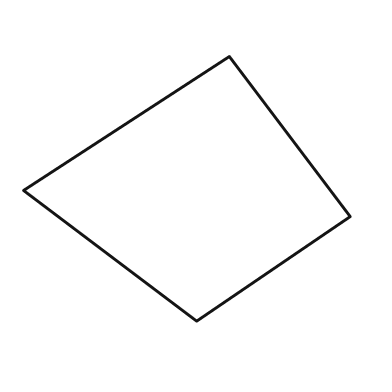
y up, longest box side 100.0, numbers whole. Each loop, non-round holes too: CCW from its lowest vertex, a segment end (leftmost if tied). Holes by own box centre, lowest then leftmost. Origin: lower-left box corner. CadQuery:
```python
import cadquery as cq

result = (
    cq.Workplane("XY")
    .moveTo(53.0, 0.0)
    .lineTo(100.0, 32.0)
    .lineTo(63.0, 81.0)
    .lineTo(0.0, 40.0)
    .close()
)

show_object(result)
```